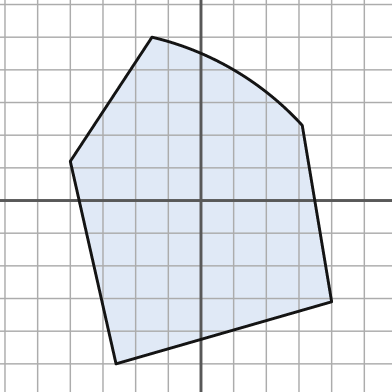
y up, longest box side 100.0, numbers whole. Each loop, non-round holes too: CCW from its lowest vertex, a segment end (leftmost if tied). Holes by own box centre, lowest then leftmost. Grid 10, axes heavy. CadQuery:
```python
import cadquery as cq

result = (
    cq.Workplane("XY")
    .moveTo(-26.0, -50.0)
    .lineTo(40.0, -31.0)
    .lineTo(31.0, 23.0)
    .threePointArc((10.0, 40.0), (-15.0, 50.0))
    .lineTo(-40.0, 12.0)
    .close()
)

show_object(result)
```